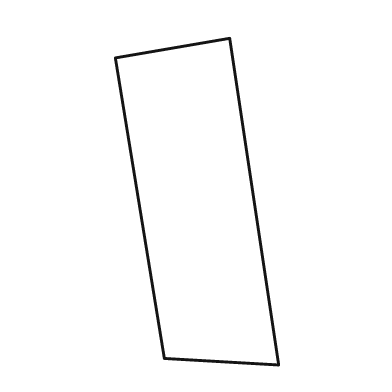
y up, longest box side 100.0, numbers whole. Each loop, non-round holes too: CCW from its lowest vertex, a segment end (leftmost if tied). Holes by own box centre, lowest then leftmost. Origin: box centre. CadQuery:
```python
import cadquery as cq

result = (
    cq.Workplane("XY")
    .moveTo(25.0, -50.0)
    .lineTo(10.0, 50.0)
    .lineTo(-25.0, 44.0)
    .lineTo(-10.0, -48.0)
    .close()
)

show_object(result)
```